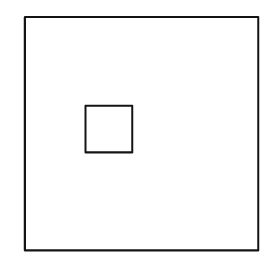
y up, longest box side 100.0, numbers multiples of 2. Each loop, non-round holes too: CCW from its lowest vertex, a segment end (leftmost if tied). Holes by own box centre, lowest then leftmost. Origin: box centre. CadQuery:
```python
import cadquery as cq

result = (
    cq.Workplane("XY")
    .moveTo(-50.0, -50.0)
    .lineTo(50.0, -50.0)
    .lineTo(50.0, 50.0)
    .lineTo(-50.0, 50.0)
    .close()
    .moveTo(-24.0, -8.0)
    .lineTo(-4.0, -8.0)
    .lineTo(-4.0, 12.0)
    .lineTo(-24.0, 12.0)
    .close()
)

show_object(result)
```